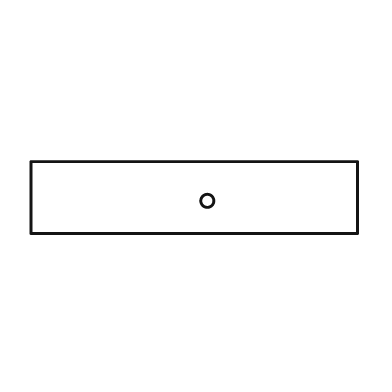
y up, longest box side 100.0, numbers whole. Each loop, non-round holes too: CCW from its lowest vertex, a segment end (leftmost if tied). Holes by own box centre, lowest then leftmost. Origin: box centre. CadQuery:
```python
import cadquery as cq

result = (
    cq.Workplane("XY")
    .moveTo(-50.0, -11.0)
    .lineTo(50.0, -11.0)
    .lineTo(50.0, 11.0)
    .lineTo(-50.0, 11.0)
    .close()
    .moveTo(4.0, -1.0)
    .circle(2.0)
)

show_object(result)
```